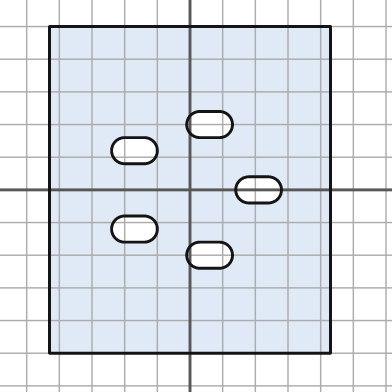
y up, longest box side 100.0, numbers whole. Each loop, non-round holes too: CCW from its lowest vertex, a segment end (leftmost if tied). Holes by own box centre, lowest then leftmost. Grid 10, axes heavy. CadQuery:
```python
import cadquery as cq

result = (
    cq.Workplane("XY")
    .moveTo(-43.0, -50.0)
    .lineTo(43.0, -50.0)
    .lineTo(43.0, 50.0)
    .lineTo(-43.0, 50.0)
    .close()
    .moveTo(3.0, -24.0)
    .lineTo(9.0, -24.0)
    .threePointArc((13.0, -20.0), (9.0, -16.0))
    .lineTo(3.0, -16.0)
    .threePointArc((-1.0, -20.0), (3.0, -24.0))
    .close()
    .moveTo(-20.0, -16.0)
    .lineTo(-14.0, -16.0)
    .threePointArc((-10.0, -12.0), (-14.0, -8.0))
    .lineTo(-20.0, -8.0)
    .threePointArc((-24.0, -12.0), (-20.0, -16.0))
    .close()
    .moveTo(18.0, -4.0)
    .lineTo(24.0, -4.0)
    .threePointArc((28.0, 0.0), (24.0, 4.0))
    .lineTo(18.0, 4.0)
    .threePointArc((14.0, 0.0), (18.0, -4.0))
    .close()
    .moveTo(-20.0, 8.0)
    .lineTo(-14.0, 8.0)
    .threePointArc((-10.0, 12.0), (-14.0, 16.0))
    .lineTo(-20.0, 16.0)
    .threePointArc((-24.0, 12.0), (-20.0, 8.0))
    .close()
    .moveTo(3.0, 16.0)
    .lineTo(9.0, 16.0)
    .threePointArc((13.0, 20.0), (9.0, 24.0))
    .lineTo(3.0, 24.0)
    .threePointArc((-1.0, 20.0), (3.0, 16.0))
    .close()
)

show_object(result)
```